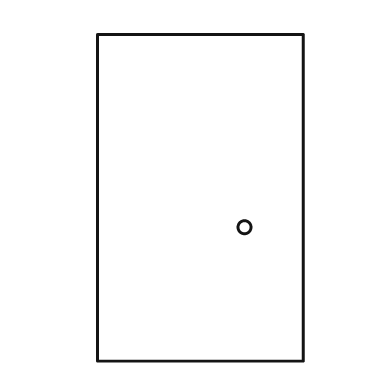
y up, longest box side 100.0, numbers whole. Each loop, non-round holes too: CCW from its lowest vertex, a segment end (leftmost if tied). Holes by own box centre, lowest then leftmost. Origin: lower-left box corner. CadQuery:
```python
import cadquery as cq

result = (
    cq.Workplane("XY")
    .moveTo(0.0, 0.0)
    .lineTo(63.0, 0.0)
    .lineTo(63.0, 100.0)
    .lineTo(0.0, 100.0)
    .close()
    .moveTo(45.0, 41.0)
    .circle(2.0)
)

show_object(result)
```